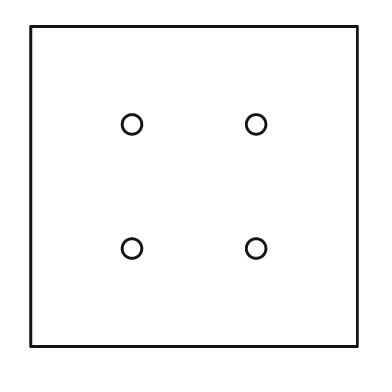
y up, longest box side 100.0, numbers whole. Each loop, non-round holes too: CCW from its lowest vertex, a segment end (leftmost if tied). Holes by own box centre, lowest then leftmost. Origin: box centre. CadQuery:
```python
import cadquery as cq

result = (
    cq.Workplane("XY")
    .moveTo(-50.0, -49.0)
    .lineTo(50.0, -49.0)
    .lineTo(50.0, 49.0)
    .lineTo(-50.0, 49.0)
    .close()
    .moveTo(-19.0, -19.0)
    .circle(3.0)
    .moveTo(19.0, -19.0)
    .circle(3.0)
    .moveTo(-19.0, 19.0)
    .circle(3.0)
    .moveTo(19.0, 19.0)
    .circle(3.0)
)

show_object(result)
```